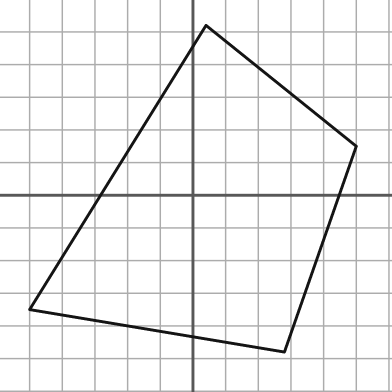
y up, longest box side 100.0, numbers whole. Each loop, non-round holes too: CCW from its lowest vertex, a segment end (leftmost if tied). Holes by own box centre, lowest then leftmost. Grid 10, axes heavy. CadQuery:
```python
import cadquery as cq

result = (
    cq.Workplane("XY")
    .moveTo(28.0, -48.0)
    .lineTo(50.0, 15.0)
    .lineTo(4.0, 52.0)
    .lineTo(-50.0, -35.0)
    .close()
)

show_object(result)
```